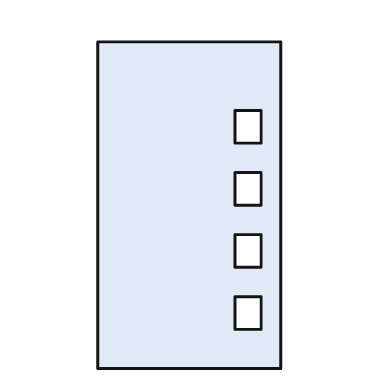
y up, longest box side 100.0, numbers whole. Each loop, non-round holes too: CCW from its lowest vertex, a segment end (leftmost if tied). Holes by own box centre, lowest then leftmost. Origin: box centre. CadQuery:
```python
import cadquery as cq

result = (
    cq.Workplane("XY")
    .moveTo(-28.0, -50.0)
    .lineTo(28.0, -50.0)
    .lineTo(28.0, 50.0)
    .lineTo(-28.0, 50.0)
    .close()
    .moveTo(14.0, -38.0)
    .lineTo(22.0, -38.0)
    .lineTo(22.0, -28.0)
    .lineTo(14.0, -28.0)
    .close()
    .moveTo(14.0, -19.0)
    .lineTo(22.0, -19.0)
    .lineTo(22.0, -9.0)
    .lineTo(14.0, -9.0)
    .close()
    .moveTo(14.0, 0.0)
    .lineTo(22.0, 0.0)
    .lineTo(22.0, 10.0)
    .lineTo(14.0, 10.0)
    .close()
    .moveTo(14.0, 19.0)
    .lineTo(22.0, 19.0)
    .lineTo(22.0, 29.0)
    .lineTo(14.0, 29.0)
    .close()
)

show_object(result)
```